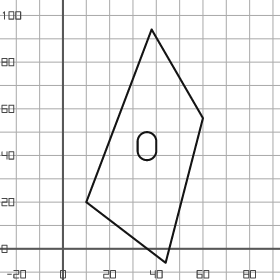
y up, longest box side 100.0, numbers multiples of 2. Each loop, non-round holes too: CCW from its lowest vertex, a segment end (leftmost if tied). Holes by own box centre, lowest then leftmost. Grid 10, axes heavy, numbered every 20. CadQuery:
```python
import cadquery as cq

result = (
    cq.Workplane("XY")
    .moveTo(44.0, -6.0)
    .lineTo(60.0, 56.0)
    .lineTo(38.0, 94.0)
    .lineTo(10.0, 20.0)
    .close()
    .moveTo(32.0, 42.0)
    .threePointArc((36.0, 38.0), (40.0, 42.0))
    .lineTo(40.0, 46.0)
    .threePointArc((36.0, 50.0), (32.0, 46.0))
    .close()
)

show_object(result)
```